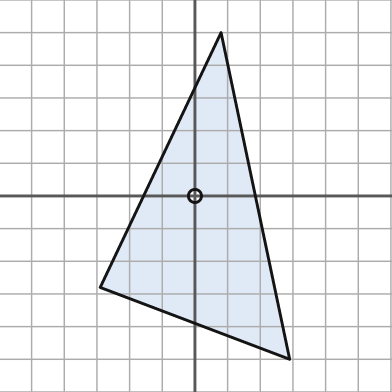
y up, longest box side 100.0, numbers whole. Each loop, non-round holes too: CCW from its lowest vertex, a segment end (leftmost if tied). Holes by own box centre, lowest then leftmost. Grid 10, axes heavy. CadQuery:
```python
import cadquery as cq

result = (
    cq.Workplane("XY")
    .moveTo(29.0, -50.0)
    .lineTo(8.0, 50.0)
    .lineTo(-29.0, -28.0)
    .close()
    .moveTo(0.0, 0.0)
    .circle(2.0)
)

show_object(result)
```